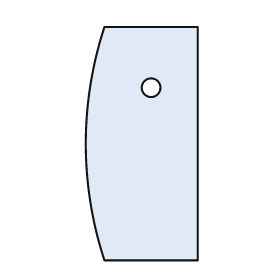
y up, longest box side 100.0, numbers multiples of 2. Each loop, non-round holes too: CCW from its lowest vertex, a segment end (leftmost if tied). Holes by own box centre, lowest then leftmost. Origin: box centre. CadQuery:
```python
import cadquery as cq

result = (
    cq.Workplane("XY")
    .moveTo(-16.0, -50.0)
    .lineTo(24.0, -50.0)
    .lineTo(24.0, 50.0)
    .lineTo(-16.0, 50.0)
    .threePointArc((-24.0, 0.0), (-16.0, -50.0))
    .close()
    .moveTo(4.0, 24.0)
    .circle(4.0)
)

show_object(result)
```